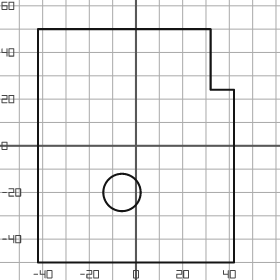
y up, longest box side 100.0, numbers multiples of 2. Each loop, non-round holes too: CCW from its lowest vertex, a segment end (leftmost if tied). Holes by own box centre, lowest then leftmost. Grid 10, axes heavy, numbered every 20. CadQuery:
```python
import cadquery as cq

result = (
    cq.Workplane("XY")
    .moveTo(-42.0, -50.0)
    .lineTo(42.0, -50.0)
    .lineTo(42.0, 24.0)
    .lineTo(32.0, 24.0)
    .lineTo(32.0, 50.0)
    .lineTo(-42.0, 50.0)
    .close()
    .moveTo(-6.0, -20.0)
    .circle(8.0)
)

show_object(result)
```